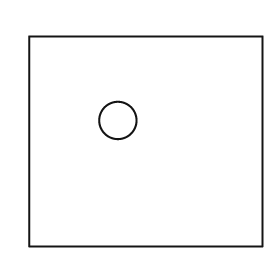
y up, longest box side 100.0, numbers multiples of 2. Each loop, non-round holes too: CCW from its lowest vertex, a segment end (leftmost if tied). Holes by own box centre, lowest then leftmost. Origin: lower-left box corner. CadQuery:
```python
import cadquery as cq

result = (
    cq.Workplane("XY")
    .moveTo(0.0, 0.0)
    .lineTo(100.0, 0.0)
    .lineTo(100.0, 90.0)
    .lineTo(0.0, 90.0)
    .close()
    .moveTo(38.0, 54.0)
    .circle(8.0)
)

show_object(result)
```